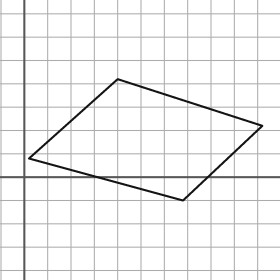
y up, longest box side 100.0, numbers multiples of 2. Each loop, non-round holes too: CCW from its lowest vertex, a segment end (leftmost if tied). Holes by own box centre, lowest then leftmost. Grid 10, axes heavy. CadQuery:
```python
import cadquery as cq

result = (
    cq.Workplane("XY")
    .moveTo(68.0, -10.0)
    .lineTo(102.0, 22.0)
    .lineTo(40.0, 42.0)
    .lineTo(2.0, 8.0)
    .close()
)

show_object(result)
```